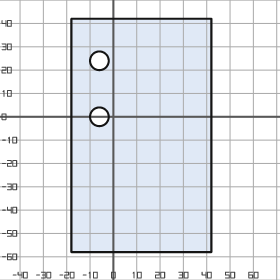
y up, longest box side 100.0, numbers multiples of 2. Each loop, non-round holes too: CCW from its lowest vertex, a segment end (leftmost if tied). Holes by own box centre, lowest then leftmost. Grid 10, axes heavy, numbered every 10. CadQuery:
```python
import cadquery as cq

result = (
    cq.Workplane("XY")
    .moveTo(-18.0, -58.0)
    .lineTo(42.0, -58.0)
    .lineTo(42.0, 42.0)
    .lineTo(-18.0, 42.0)
    .close()
    .moveTo(-6.0, 0.0)
    .circle(4.0)
    .moveTo(-6.0, 24.0)
    .circle(4.0)
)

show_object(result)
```